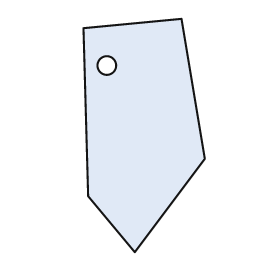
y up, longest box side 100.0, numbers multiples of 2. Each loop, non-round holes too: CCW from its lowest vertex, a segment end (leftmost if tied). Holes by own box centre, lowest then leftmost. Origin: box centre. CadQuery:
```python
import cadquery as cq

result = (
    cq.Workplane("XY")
    .moveTo(-4.0, -50.0)
    .lineTo(26.0, -10.0)
    .lineTo(16.0, 50.0)
    .lineTo(-26.0, 46.0)
    .lineTo(-24.0, -26.0)
    .close()
    .moveTo(-16.0, 30.0)
    .circle(4.0)
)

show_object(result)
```